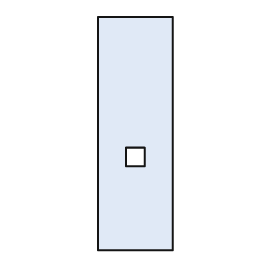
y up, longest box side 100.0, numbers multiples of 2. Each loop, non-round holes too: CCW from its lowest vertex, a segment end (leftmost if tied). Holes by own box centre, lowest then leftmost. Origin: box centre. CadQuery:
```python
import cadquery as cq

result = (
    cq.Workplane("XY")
    .moveTo(-16.0, -50.0)
    .lineTo(16.0, -50.0)
    .lineTo(16.0, 50.0)
    .lineTo(-16.0, 50.0)
    .close()
    .moveTo(-4.0, -14.0)
    .lineTo(4.0, -14.0)
    .lineTo(4.0, -6.0)
    .lineTo(-4.0, -6.0)
    .close()
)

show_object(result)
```